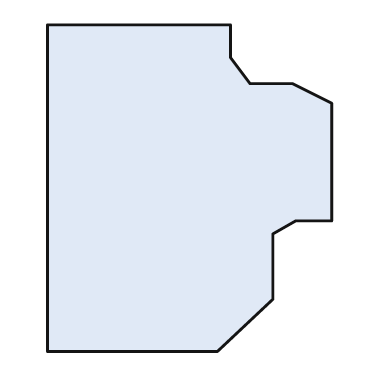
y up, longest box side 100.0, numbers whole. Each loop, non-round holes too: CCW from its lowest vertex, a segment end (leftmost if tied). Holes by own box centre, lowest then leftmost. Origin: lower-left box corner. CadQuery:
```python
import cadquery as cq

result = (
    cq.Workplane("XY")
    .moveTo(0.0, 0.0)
    .lineTo(52.0, 0.0)
    .lineTo(69.0, 16.0)
    .lineTo(69.0, 36.0)
    .lineTo(76.0, 40.0)
    .lineTo(87.0, 40.0)
    .lineTo(87.0, 76.0)
    .lineTo(75.0, 82.0)
    .lineTo(62.0, 82.0)
    .lineTo(56.0, 90.0)
    .lineTo(56.0, 100.0)
    .lineTo(0.0, 100.0)
    .close()
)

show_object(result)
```